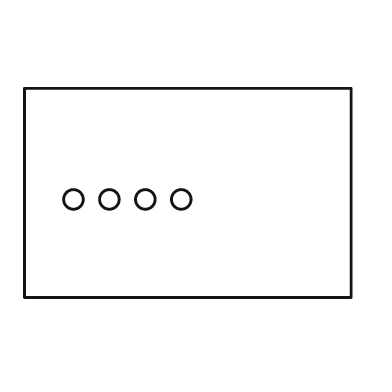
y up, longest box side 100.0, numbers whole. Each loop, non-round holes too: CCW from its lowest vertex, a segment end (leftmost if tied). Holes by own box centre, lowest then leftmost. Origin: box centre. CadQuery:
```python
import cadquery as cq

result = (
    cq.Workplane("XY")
    .moveTo(-50.0, -32.0)
    .lineTo(50.0, -32.0)
    .lineTo(50.0, 32.0)
    .lineTo(-50.0, 32.0)
    .close()
    .moveTo(-35.0, -2.0)
    .circle(3.0)
    .moveTo(-24.0, -2.0)
    .circle(3.0)
    .moveTo(-13.0, -2.0)
    .circle(3.0)
    .moveTo(-2.0, -2.0)
    .circle(3.0)
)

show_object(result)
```